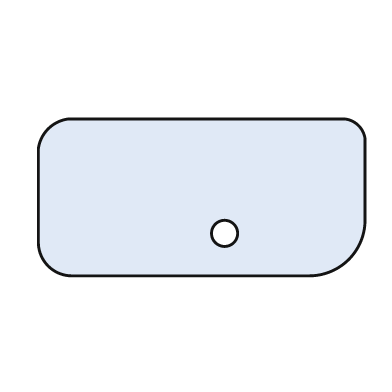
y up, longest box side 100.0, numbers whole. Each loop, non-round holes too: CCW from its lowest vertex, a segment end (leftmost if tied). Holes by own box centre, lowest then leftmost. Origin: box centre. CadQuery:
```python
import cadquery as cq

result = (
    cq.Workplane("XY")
    .moveTo(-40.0, -24.0)
    .lineTo(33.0, -24.0)
    .threePointArc((45.0, -19.0), (50.0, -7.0))
    .lineTo(50.0, 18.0)
    .threePointArc((48.0, 22.0), (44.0, 24.0))
    .lineTo(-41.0, 24.0)
    .threePointArc((-47.0, 21.0), (-50.0, 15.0))
    .lineTo(-50.0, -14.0)
    .threePointArc((-47.0, -21.0), (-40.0, -24.0))
    .close()
    .moveTo(7.0, -11.0)
    .circle(4.0)
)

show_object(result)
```